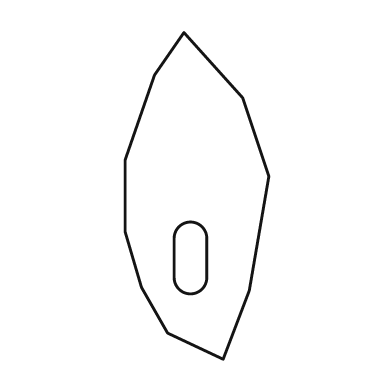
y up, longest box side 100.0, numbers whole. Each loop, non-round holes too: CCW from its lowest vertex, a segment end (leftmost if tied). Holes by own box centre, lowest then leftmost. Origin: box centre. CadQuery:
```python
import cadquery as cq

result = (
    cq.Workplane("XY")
    .moveTo(8.0, -50.0)
    .lineTo(16.0, -29.0)
    .lineTo(22.0, 6.0)
    .lineTo(14.0, 30.0)
    .lineTo(-4.0, 50.0)
    .lineTo(-13.0, 37.0)
    .lineTo(-22.0, 11.0)
    .lineTo(-22.0, -11.0)
    .lineTo(-17.0, -28.0)
    .lineTo(-9.0, -42.0)
    .close()
    .moveTo(-7.0, -25.0)
    .threePointArc((-2.0, -30.0), (3.0, -25.0))
    .lineTo(3.0, -13.0)
    .threePointArc((-2.0, -8.0), (-7.0, -13.0))
    .close()
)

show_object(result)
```